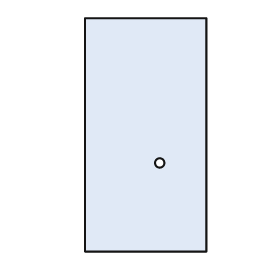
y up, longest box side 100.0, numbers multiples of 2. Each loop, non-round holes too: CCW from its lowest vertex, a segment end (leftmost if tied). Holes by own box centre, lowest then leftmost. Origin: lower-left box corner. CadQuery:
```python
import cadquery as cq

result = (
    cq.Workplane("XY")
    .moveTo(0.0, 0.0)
    .lineTo(52.0, 0.0)
    .lineTo(52.0, 100.0)
    .lineTo(0.0, 100.0)
    .close()
    .moveTo(32.0, 38.0)
    .circle(2.0)
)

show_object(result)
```